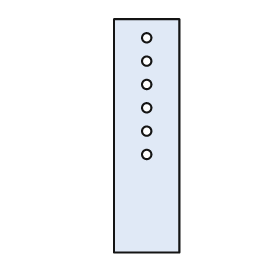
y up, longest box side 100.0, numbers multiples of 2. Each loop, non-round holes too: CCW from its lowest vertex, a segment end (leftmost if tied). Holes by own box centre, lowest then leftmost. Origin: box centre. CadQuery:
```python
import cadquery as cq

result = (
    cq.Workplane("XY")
    .moveTo(-14.0, -50.0)
    .lineTo(14.0, -50.0)
    .lineTo(14.0, 50.0)
    .lineTo(-14.0, 50.0)
    .close()
    .moveTo(0.0, -8.0)
    .circle(2.0)
    .moveTo(0.0, 2.0)
    .circle(2.0)
    .moveTo(0.0, 12.0)
    .circle(2.0)
    .moveTo(0.0, 22.0)
    .circle(2.0)
    .moveTo(0.0, 32.0)
    .circle(2.0)
    .moveTo(0.0, 42.0)
    .circle(2.0)
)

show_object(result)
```